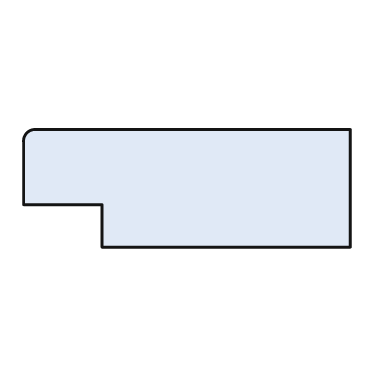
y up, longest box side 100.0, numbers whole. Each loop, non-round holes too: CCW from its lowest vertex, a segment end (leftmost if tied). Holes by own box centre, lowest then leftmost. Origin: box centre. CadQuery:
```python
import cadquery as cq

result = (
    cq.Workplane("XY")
    .moveTo(-26.0, -18.0)
    .lineTo(50.0, -18.0)
    .lineTo(50.0, 18.0)
    .lineTo(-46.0, 18.0)
    .threePointArc((-49.0, 17.0), (-50.0, 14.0))
    .lineTo(-50.0, -5.0)
    .lineTo(-26.0, -5.0)
    .close()
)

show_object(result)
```